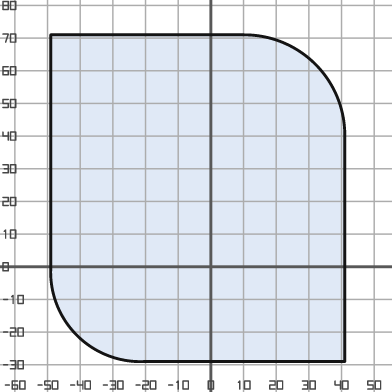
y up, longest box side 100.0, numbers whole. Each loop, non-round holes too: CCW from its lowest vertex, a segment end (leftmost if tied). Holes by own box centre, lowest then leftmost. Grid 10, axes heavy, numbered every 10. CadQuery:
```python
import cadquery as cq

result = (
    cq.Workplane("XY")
    .moveTo(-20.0, -29.0)
    .lineTo(41.0, -29.0)
    .lineTo(41.0, 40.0)
    .threePointArc((32.0, 62.0), (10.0, 71.0))
    .lineTo(-49.0, 71.0)
    .lineTo(-49.0, 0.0)
    .threePointArc((-41.0, -21.0), (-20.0, -29.0))
    .close()
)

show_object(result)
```